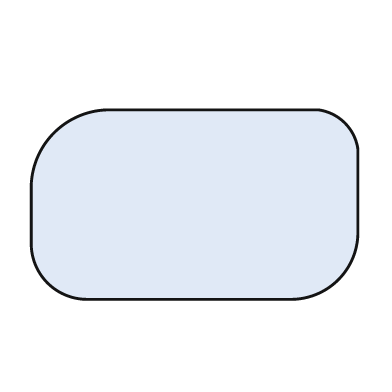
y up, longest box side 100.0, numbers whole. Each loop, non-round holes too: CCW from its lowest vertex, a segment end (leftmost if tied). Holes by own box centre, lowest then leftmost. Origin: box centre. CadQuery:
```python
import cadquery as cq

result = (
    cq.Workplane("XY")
    .moveTo(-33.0, -29.0)
    .lineTo(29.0, -29.0)
    .threePointArc((44.0, -23.0), (50.0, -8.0))
    .lineTo(50.0, 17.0)
    .threePointArc((46.0, 25.0), (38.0, 29.0))
    .lineTo(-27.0, 29.0)
    .threePointArc((-43.0, 22.0), (-50.0, 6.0))
    .lineTo(-50.0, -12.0)
    .threePointArc((-45.0, -24.0), (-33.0, -29.0))
    .close()
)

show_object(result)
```